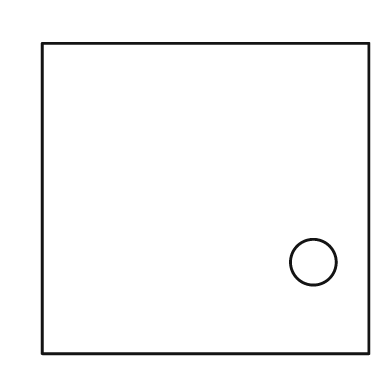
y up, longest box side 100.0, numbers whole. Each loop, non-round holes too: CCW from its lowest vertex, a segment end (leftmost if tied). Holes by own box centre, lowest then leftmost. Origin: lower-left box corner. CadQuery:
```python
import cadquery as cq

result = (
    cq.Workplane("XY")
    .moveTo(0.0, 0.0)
    .lineTo(100.0, 0.0)
    .lineTo(100.0, 95.0)
    .lineTo(0.0, 95.0)
    .close()
    .moveTo(83.0, 28.0)
    .circle(7.0)
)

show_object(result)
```